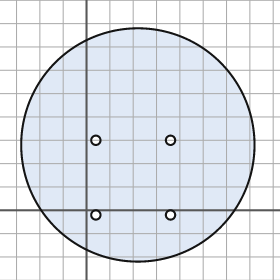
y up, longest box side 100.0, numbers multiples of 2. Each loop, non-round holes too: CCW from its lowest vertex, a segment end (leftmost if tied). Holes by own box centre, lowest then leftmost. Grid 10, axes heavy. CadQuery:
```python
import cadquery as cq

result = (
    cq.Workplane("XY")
    .moveTo(22.0, 28.0)
    .circle(50.0)
    .moveTo(4.0, -2.0)
    .circle(2.0)
    .moveTo(36.0, -2.0)
    .circle(2.0)
    .moveTo(4.0, 30.0)
    .circle(2.0)
    .moveTo(36.0, 30.0)
    .circle(2.0)
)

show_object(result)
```